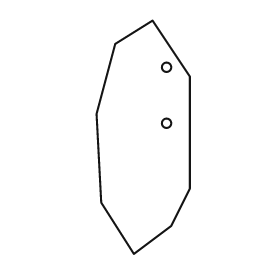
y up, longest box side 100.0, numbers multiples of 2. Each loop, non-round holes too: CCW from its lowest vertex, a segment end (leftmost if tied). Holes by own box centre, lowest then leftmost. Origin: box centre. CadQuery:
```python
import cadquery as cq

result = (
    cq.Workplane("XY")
    .moveTo(-4.0, -50.0)
    .lineTo(12.0, -38.0)
    .lineTo(20.0, -22.0)
    .lineTo(20.0, 26.0)
    .lineTo(4.0, 50.0)
    .lineTo(-12.0, 40.0)
    .lineTo(-20.0, 10.0)
    .lineTo(-18.0, -28.0)
    .close()
    .moveTo(10.0, 6.0)
    .circle(2.0)
    .moveTo(10.0, 30.0)
    .circle(2.0)
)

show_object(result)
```